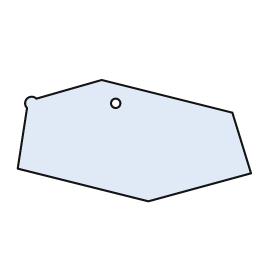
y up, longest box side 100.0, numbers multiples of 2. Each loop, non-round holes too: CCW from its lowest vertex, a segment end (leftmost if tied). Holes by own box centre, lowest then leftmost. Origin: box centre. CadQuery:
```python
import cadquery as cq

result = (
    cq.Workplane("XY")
    .moveTo(6.0, -26.0)
    .lineTo(50.0, -14.0)
    .lineTo(42.0, 12.0)
    .lineTo(-14.0, 26.0)
    .lineTo(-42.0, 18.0)
    .threePointArc((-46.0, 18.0), (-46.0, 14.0))
    .lineTo(-50.0, -12.0)
    .close()
    .moveTo(-8.0, 16.0)
    .circle(2.0)
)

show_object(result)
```